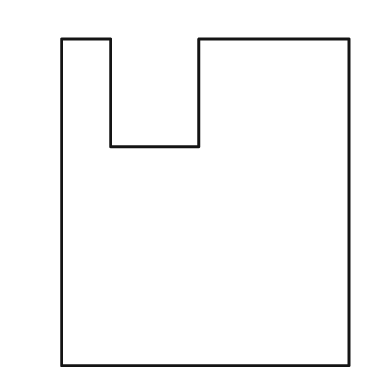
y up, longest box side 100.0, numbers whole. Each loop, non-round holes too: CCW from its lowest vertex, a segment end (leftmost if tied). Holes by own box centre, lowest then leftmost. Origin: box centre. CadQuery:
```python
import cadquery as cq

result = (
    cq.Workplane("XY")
    .moveTo(-44.0, -50.0)
    .lineTo(44.0, -50.0)
    .lineTo(44.0, 50.0)
    .lineTo(-2.0, 50.0)
    .lineTo(-2.0, 17.0)
    .lineTo(-29.0, 17.0)
    .lineTo(-29.0, 50.0)
    .lineTo(-44.0, 50.0)
    .close()
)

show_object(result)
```